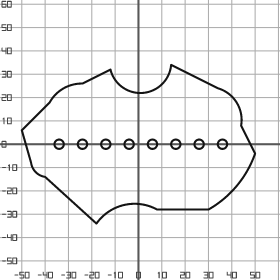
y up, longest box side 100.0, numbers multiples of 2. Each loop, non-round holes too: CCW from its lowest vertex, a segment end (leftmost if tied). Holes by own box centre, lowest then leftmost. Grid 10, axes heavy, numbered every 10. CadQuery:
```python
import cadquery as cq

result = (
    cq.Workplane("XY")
    .moveTo(-18.0, -34.0)
    .threePointArc((-6.0, -26.0), (8.0, -28.0))
    .lineTo(30.0, -28.0)
    .threePointArc((42.0, -18.0), (50.0, -4.0))
    .lineTo(44.0, 8.0)
    .threePointArc((42.0, 18.0), (34.0, 24.0))
    .lineTo(14.0, 34.0)
    .threePointArc((2.0, 22.0), (-12.0, 32.0))
    .lineTo(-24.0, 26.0)
    .threePointArc((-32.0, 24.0), (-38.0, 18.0))
    .lineTo(-50.0, 6.0)
    .lineTo(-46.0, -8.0)
    .threePointArc((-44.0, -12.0), (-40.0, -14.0))
    .close()
    .moveTo(-34.0, 0.0)
    .circle(2.0)
    .moveTo(-24.0, 0.0)
    .circle(2.0)
    .moveTo(-14.0, 0.0)
    .circle(2.0)
    .moveTo(-4.0, 0.0)
    .circle(2.0)
    .moveTo(6.0, 0.0)
    .circle(2.0)
    .moveTo(16.0, 0.0)
    .circle(2.0)
    .moveTo(26.0, 0.0)
    .circle(2.0)
    .moveTo(36.0, 0.0)
    .circle(2.0)
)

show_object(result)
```